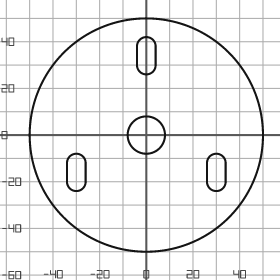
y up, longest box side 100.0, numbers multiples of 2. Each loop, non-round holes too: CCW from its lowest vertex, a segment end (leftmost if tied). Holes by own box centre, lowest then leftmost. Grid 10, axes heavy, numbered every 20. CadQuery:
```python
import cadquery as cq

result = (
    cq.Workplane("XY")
    .moveTo(0.0, 0.0)
    .circle(50.0)
    .moveTo(-34.0, -20.0)
    .threePointArc((-30.0, -24.0), (-26.0, -20.0))
    .lineTo(-26.0, -12.0)
    .threePointArc((-30.0, -8.0), (-34.0, -12.0))
    .close()
    .moveTo(26.0, -20.0)
    .threePointArc((30.0, -24.0), (34.0, -20.0))
    .lineTo(34.0, -12.0)
    .threePointArc((30.0, -8.0), (26.0, -12.0))
    .close()
    .moveTo(0.0, 0.0)
    .circle(8.0)
    .moveTo(-4.0, 30.0)
    .threePointArc((0.0, 26.0), (4.0, 30.0))
    .lineTo(4.0, 38.0)
    .threePointArc((0.0, 42.0), (-4.0, 38.0))
    .close()
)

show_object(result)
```